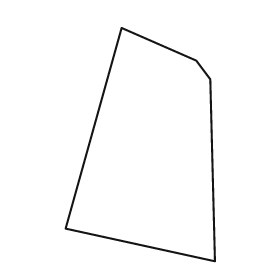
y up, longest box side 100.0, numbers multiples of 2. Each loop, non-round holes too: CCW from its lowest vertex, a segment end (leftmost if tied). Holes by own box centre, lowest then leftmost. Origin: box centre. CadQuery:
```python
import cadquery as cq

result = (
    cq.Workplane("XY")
    .moveTo(32.0, -50.0)
    .lineTo(30.0, 28.0)
    .lineTo(24.0, 36.0)
    .lineTo(-8.0, 50.0)
    .lineTo(-32.0, -36.0)
    .close()
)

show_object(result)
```